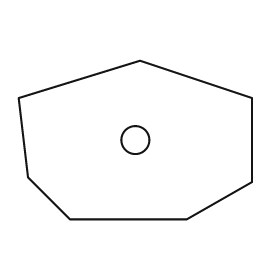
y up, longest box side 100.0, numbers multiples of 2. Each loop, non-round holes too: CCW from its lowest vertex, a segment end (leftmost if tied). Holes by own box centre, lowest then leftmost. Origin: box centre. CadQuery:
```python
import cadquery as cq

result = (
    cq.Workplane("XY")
    .moveTo(-28.0, -34.0)
    .lineTo(22.0, -34.0)
    .lineTo(50.0, -18.0)
    .lineTo(50.0, 18.0)
    .lineTo(2.0, 34.0)
    .lineTo(-50.0, 18.0)
    .lineTo(-46.0, -16.0)
    .close()
    .moveTo(0.0, 0.0)
    .circle(6.0)
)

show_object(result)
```